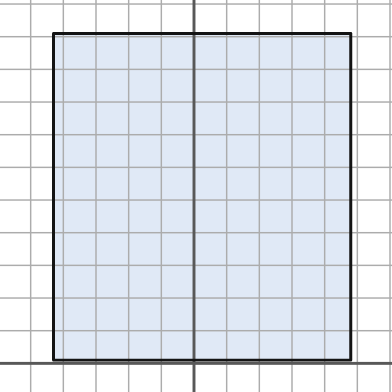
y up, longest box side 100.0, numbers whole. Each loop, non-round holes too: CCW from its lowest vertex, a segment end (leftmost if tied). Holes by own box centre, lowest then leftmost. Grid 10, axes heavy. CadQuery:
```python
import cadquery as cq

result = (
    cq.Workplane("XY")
    .moveTo(-43.0, 1.0)
    .lineTo(48.0, 1.0)
    .lineTo(48.0, 101.0)
    .lineTo(-43.0, 101.0)
    .close()
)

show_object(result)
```